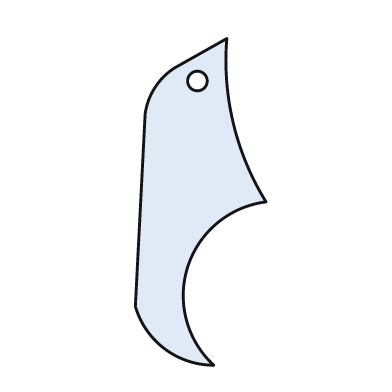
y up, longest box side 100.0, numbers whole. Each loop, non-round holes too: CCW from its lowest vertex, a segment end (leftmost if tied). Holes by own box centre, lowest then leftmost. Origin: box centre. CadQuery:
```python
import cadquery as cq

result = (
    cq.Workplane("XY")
    .moveTo(4.0, -50.0)
    .threePointArc((-4.0, -20.0), (20.0, 0.0))
    .threePointArc((10.0, 24.0), (8.0, 50.0))
    .lineTo(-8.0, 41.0)
    .threePointArc((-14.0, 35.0), (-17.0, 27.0))
    .lineTo(-20.0, -32.0)
    .threePointArc((-11.0, -45.0), (4.0, -50.0))
    .close()
    .moveTo(-1.0, 37.0)
    .circle(3.0)
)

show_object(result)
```